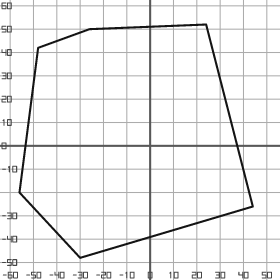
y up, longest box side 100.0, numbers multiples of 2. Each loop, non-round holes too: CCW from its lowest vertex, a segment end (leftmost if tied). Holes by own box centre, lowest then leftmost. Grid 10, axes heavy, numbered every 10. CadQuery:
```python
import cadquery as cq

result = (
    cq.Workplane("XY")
    .moveTo(-30.0, -48.0)
    .lineTo(44.0, -26.0)
    .lineTo(24.0, 52.0)
    .lineTo(-26.0, 50.0)
    .lineTo(-48.0, 42.0)
    .lineTo(-56.0, -20.0)
    .close()
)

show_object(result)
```